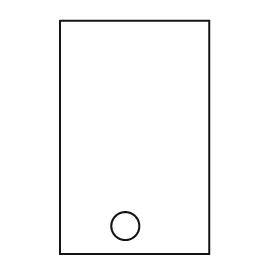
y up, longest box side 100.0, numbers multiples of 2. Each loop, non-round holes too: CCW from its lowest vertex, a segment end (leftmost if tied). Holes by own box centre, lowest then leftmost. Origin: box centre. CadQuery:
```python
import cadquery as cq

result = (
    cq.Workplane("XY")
    .moveTo(-32.0, -50.0)
    .lineTo(32.0, -50.0)
    .lineTo(32.0, 50.0)
    .lineTo(-32.0, 50.0)
    .close()
    .moveTo(-4.0, -38.0)
    .circle(6.0)
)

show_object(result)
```